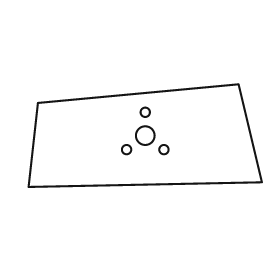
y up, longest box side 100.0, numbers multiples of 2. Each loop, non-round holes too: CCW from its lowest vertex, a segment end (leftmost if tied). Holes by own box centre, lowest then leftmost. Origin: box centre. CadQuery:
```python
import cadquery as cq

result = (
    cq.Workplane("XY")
    .moveTo(-50.0, -22.0)
    .lineTo(50.0, -20.0)
    .lineTo(40.0, 22.0)
    .lineTo(-46.0, 14.0)
    .close()
    .moveTo(-8.0, -6.0)
    .circle(2.0)
    .moveTo(8.0, -6.0)
    .circle(2.0)
    .moveTo(0.0, 0.0)
    .circle(4.0)
    .moveTo(0.0, 10.0)
    .circle(2.0)
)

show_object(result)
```